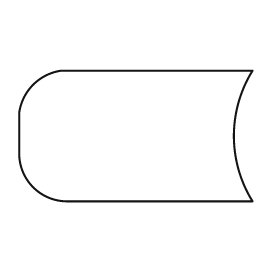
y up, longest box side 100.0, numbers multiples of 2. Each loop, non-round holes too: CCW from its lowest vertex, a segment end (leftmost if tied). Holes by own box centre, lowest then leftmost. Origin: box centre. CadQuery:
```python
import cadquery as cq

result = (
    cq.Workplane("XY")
    .moveTo(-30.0, -28.0)
    .lineTo(50.0, -28.0)
    .threePointArc((42.0, 0.0), (50.0, 28.0))
    .lineTo(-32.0, 28.0)
    .threePointArc((-44.0, 22.0), (-50.0, 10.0))
    .lineTo(-50.0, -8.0)
    .threePointArc((-44.0, -22.0), (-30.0, -28.0))
    .close()
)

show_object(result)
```